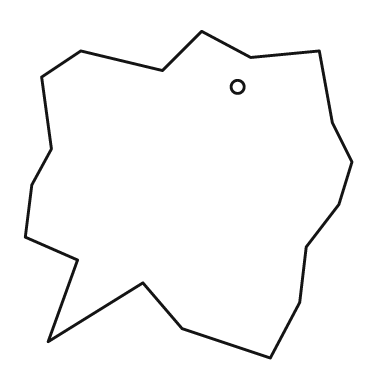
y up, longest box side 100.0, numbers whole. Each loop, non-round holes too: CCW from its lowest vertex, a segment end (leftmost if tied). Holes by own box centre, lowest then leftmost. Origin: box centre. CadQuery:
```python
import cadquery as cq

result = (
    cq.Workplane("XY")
    .moveTo(25.0, -50.0)
    .lineTo(34.0, -33.0)
    .lineTo(36.0, -16.0)
    .lineTo(46.0, -3.0)
    .lineTo(50.0, 10.0)
    .lineTo(44.0, 22.0)
    .lineTo(40.0, 44.0)
    .lineTo(19.0, 42.0)
    .lineTo(4.0, 50.0)
    .lineTo(-8.0, 38.0)
    .lineTo(-33.0, 44.0)
    .lineTo(-45.0, 36.0)
    .lineTo(-42.0, 14.0)
    .lineTo(-48.0, 3.0)
    .lineTo(-50.0, -13.0)
    .lineTo(-34.0, -20.0)
    .lineTo(-43.0, -45.0)
    .lineTo(-14.0, -27.0)
    .lineTo(-2.0, -41.0)
    .close()
    .moveTo(15.0, 33.0)
    .circle(2.0)
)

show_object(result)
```